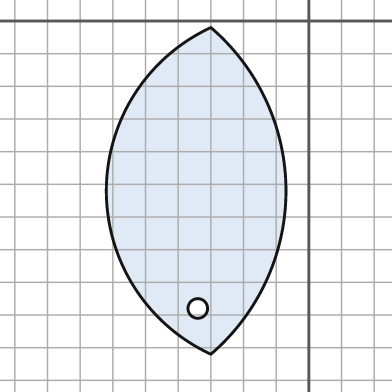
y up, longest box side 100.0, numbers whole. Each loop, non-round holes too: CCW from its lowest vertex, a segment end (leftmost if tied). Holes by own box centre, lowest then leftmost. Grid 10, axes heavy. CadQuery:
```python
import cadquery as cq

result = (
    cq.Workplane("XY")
    .moveTo(-30.0, -102.0)
    .threePointArc((-7.0, -52.0), (-30.0, -2.0))
    .threePointArc((-62.0, -52.0), (-30.0, -102.0))
    .close()
    .moveTo(-34.0, -88.0)
    .circle(3.0)
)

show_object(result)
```